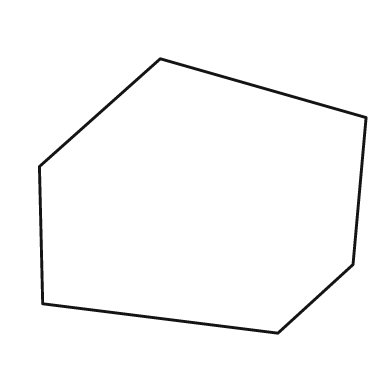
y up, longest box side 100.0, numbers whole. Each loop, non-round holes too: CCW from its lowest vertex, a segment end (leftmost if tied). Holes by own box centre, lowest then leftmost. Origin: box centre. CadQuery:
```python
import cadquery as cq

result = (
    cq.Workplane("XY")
    .moveTo(23.0, -42.0)
    .lineTo(46.0, -21.0)
    .lineTo(50.0, 24.0)
    .lineTo(-13.0, 42.0)
    .lineTo(-50.0, 9.0)
    .lineTo(-49.0, -33.0)
    .close()
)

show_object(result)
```